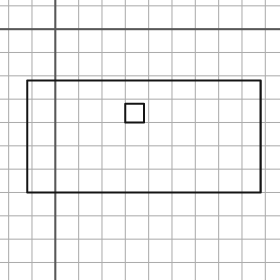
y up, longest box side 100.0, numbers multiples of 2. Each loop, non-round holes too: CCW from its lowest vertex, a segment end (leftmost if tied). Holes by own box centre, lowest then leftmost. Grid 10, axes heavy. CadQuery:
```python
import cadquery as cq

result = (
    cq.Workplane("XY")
    .moveTo(-12.0, -70.0)
    .lineTo(88.0, -70.0)
    .lineTo(88.0, -22.0)
    .lineTo(-12.0, -22.0)
    .close()
    .moveTo(30.0, -40.0)
    .lineTo(38.0, -40.0)
    .lineTo(38.0, -32.0)
    .lineTo(30.0, -32.0)
    .close()
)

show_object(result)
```